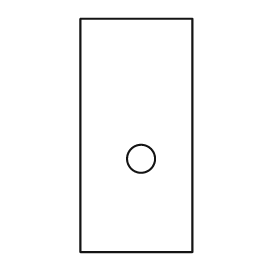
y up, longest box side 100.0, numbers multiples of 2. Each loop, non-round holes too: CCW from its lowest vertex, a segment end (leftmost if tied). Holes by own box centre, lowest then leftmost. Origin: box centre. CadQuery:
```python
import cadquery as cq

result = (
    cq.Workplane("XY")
    .moveTo(-24.0, -50.0)
    .lineTo(24.0, -50.0)
    .lineTo(24.0, 50.0)
    .lineTo(-24.0, 50.0)
    .close()
    .moveTo(2.0, -10.0)
    .circle(6.0)
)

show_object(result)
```